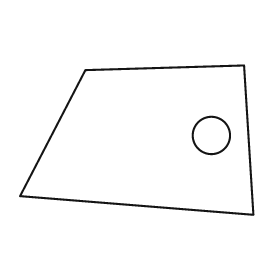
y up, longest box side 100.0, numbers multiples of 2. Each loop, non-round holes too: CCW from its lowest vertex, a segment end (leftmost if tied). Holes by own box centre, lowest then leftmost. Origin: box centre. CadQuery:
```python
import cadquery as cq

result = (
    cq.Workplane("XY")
    .moveTo(50.0, -32.0)
    .lineTo(46.0, 32.0)
    .lineTo(-22.0, 30.0)
    .lineTo(-50.0, -24.0)
    .close()
    .moveTo(32.0, 2.0)
    .circle(8.0)
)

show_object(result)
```